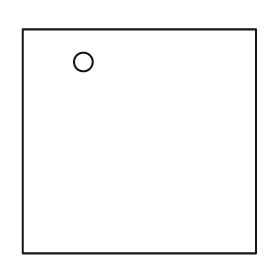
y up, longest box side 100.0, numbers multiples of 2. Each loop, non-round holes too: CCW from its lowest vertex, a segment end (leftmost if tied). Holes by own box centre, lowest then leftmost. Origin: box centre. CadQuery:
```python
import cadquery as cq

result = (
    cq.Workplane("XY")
    .moveTo(-50.0, -48.0)
    .lineTo(50.0, -48.0)
    .lineTo(50.0, 48.0)
    .lineTo(-50.0, 48.0)
    .close()
    .moveTo(-24.0, 34.0)
    .circle(4.0)
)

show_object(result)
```